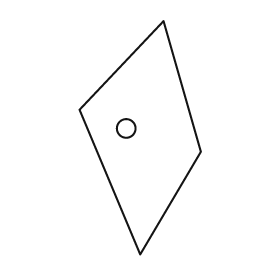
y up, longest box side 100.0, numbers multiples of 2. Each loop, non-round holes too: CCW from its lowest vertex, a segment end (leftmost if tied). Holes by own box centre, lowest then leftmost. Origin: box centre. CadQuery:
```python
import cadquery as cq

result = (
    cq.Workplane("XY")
    .moveTo(0.0, -50.0)
    .lineTo(26.0, -6.0)
    .lineTo(10.0, 50.0)
    .lineTo(-26.0, 12.0)
    .close()
    .moveTo(-6.0, 4.0)
    .circle(4.0)
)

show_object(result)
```